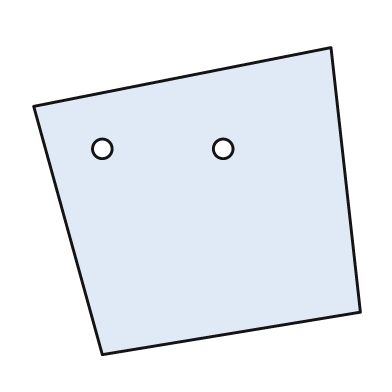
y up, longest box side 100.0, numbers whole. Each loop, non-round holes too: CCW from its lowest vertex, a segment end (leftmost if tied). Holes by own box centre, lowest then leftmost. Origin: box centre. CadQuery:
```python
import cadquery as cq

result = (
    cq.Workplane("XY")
    .moveTo(-29.0, -47.0)
    .lineTo(50.0, -34.0)
    .lineTo(41.0, 47.0)
    .lineTo(-50.0, 29.0)
    .close()
    .moveTo(-29.0, 16.0)
    .circle(3.0)
    .moveTo(8.0, 16.0)
    .circle(3.0)
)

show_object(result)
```